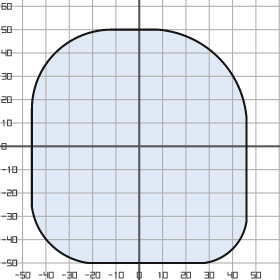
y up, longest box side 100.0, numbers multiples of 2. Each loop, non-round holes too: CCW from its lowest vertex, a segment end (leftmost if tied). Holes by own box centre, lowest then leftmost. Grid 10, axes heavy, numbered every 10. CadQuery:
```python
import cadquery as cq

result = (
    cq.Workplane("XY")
    .moveTo(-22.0, -50.0)
    .lineTo(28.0, -50.0)
    .threePointArc((40.0, -44.0), (46.0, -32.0))
    .lineTo(46.0, 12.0)
    .threePointArc((34.0, 38.0), (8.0, 50.0))
    .lineTo(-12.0, 50.0)
    .threePointArc((-36.0, 40.0), (-46.0, 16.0))
    .lineTo(-46.0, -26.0)
    .threePointArc((-38.0, -42.0), (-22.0, -50.0))
    .close()
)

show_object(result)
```